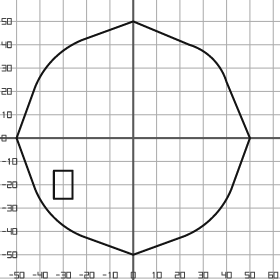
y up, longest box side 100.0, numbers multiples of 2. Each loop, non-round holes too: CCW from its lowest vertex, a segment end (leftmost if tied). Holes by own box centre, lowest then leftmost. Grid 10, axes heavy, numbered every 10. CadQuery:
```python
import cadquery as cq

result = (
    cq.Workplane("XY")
    .moveTo(0.0, -50.0)
    .lineTo(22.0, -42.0)
    .threePointArc((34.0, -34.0), (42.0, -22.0))
    .lineTo(50.0, 0.0)
    .lineTo(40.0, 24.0)
    .threePointArc((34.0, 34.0), (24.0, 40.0))
    .lineTo(0.0, 50.0)
    .lineTo(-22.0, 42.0)
    .threePointArc((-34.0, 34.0), (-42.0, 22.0))
    .lineTo(-50.0, 0.0)
    .lineTo(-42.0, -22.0)
    .threePointArc((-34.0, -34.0), (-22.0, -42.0))
    .close()
    .moveTo(-34.0, -26.0)
    .lineTo(-26.0, -26.0)
    .lineTo(-26.0, -14.0)
    .lineTo(-34.0, -14.0)
    .close()
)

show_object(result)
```